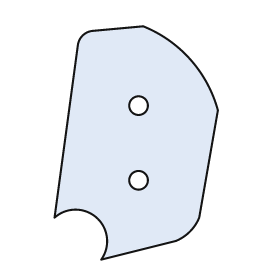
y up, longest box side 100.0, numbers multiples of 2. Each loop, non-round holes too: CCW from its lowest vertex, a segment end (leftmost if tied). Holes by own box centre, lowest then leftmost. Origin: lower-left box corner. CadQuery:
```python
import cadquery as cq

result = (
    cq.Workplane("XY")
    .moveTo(20.0, 0.0)
    .lineTo(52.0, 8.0)
    .threePointArc((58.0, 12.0), (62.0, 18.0))
    .lineTo(70.0, 64.0)
    .threePointArc((58.0, 86.0), (38.0, 100.0))
    .lineTo(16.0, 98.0)
    .threePointArc((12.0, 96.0), (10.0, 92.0))
    .lineTo(0.0, 18.0)
    .threePointArc((18.0, 18.0), (20.0, 0.0))
    .close()
    .moveTo(36.0, 34.0)
    .circle(4.0)
    .moveTo(36.0, 66.0)
    .circle(4.0)
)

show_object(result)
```